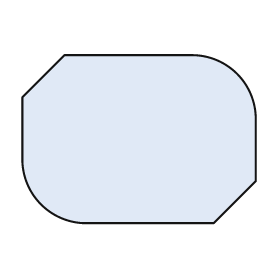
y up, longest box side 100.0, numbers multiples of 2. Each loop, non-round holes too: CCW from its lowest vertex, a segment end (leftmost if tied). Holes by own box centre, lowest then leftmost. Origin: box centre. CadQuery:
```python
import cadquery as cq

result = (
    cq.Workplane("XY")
    .moveTo(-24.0, -36.0)
    .lineTo(32.0, -36.0)
    .lineTo(50.0, -18.0)
    .lineTo(50.0, 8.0)
    .threePointArc((42.0, 28.0), (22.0, 36.0))
    .lineTo(-32.0, 36.0)
    .lineTo(-50.0, 18.0)
    .lineTo(-50.0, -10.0)
    .threePointArc((-42.0, -28.0), (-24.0, -36.0))
    .close()
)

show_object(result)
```